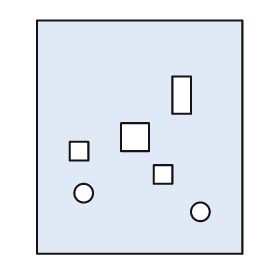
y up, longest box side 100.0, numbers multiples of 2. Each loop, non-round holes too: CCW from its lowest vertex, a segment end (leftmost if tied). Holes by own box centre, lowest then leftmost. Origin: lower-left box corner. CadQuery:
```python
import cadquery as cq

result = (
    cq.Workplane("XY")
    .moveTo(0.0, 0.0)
    .lineTo(88.0, 0.0)
    .lineTo(88.0, 100.0)
    .lineTo(0.0, 100.0)
    .close()
    .moveTo(70.0, 18.0)
    .circle(4.0)
    .moveTo(20.0, 26.0)
    .circle(4.0)
    .moveTo(50.0, 30.0)
    .lineTo(58.0, 30.0)
    .lineTo(58.0, 38.0)
    .lineTo(50.0, 38.0)
    .close()
    .moveTo(14.0, 40.0)
    .lineTo(22.0, 40.0)
    .lineTo(22.0, 48.0)
    .lineTo(14.0, 48.0)
    .close()
    .moveTo(36.0, 44.0)
    .lineTo(48.0, 44.0)
    .lineTo(48.0, 56.0)
    .lineTo(36.0, 56.0)
    .close()
    .moveTo(58.0, 60.0)
    .lineTo(66.0, 60.0)
    .lineTo(66.0, 76.0)
    .lineTo(58.0, 76.0)
    .close()
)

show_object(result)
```